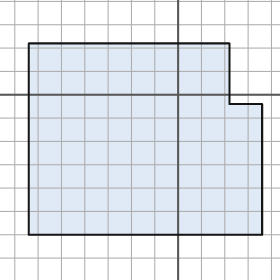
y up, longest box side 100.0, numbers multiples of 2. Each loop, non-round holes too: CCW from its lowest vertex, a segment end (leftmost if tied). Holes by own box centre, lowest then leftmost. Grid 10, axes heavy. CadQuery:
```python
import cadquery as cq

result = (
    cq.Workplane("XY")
    .moveTo(-64.0, -60.0)
    .lineTo(36.0, -60.0)
    .lineTo(36.0, -4.0)
    .lineTo(22.0, -4.0)
    .lineTo(22.0, 22.0)
    .lineTo(-64.0, 22.0)
    .close()
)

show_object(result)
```